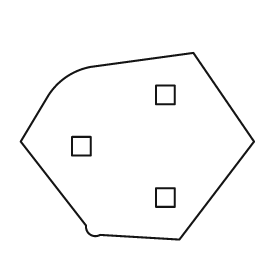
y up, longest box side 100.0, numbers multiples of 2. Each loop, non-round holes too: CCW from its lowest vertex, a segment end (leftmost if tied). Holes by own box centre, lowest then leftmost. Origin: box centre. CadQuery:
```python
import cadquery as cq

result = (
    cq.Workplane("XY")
    .moveTo(18.0, -40.0)
    .lineTo(50.0, 2.0)
    .lineTo(24.0, 40.0)
    .lineTo(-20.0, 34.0)
    .threePointArc((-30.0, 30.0), (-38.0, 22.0))
    .lineTo(-50.0, 2.0)
    .lineTo(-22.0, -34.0)
    .threePointArc((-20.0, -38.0), (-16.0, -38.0))
    .close()
    .moveTo(8.0, -26.0)
    .lineTo(16.0, -26.0)
    .lineTo(16.0, -18.0)
    .lineTo(8.0, -18.0)
    .close()
    .moveTo(-28.0, -4.0)
    .lineTo(-20.0, -4.0)
    .lineTo(-20.0, 4.0)
    .lineTo(-28.0, 4.0)
    .close()
    .moveTo(8.0, 18.0)
    .lineTo(16.0, 18.0)
    .lineTo(16.0, 26.0)
    .lineTo(8.0, 26.0)
    .close()
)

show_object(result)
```